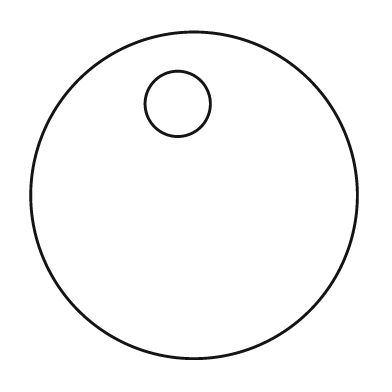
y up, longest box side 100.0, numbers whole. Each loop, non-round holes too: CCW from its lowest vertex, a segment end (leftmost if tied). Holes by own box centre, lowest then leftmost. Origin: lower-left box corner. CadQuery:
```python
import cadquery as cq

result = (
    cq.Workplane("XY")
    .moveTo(50.0, 50.0)
    .circle(50.0)
    .moveTo(45.0, 78.0)
    .circle(10.0)
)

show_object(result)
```